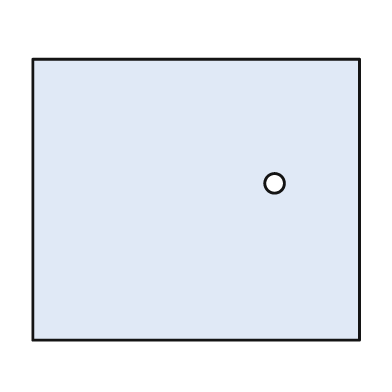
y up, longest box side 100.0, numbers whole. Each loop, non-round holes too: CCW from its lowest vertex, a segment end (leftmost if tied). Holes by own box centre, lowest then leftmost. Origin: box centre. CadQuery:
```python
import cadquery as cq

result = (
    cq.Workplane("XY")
    .moveTo(-50.0, -43.0)
    .lineTo(50.0, -43.0)
    .lineTo(50.0, 43.0)
    .lineTo(-50.0, 43.0)
    .close()
    .moveTo(24.0, 5.0)
    .circle(3.0)
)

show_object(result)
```